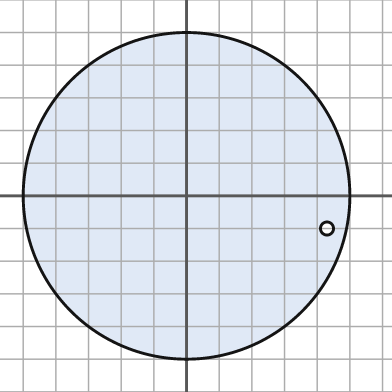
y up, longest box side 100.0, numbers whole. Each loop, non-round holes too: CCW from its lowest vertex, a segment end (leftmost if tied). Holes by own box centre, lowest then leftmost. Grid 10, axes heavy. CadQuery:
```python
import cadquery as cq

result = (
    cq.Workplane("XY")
    .moveTo(0.0, 0.0)
    .circle(50.0)
    .moveTo(43.0, -10.0)
    .circle(2.0)
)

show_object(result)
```